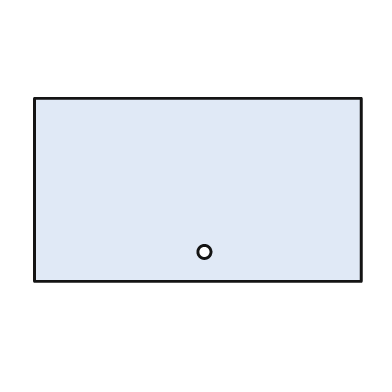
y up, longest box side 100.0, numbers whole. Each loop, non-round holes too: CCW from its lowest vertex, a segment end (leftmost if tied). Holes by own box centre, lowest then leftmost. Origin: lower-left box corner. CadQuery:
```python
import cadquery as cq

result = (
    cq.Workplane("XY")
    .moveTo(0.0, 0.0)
    .lineTo(100.0, 0.0)
    .lineTo(100.0, 56.0)
    .lineTo(0.0, 56.0)
    .close()
    .moveTo(52.0, 9.0)
    .circle(2.0)
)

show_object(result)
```